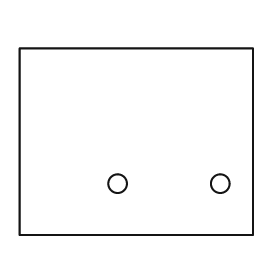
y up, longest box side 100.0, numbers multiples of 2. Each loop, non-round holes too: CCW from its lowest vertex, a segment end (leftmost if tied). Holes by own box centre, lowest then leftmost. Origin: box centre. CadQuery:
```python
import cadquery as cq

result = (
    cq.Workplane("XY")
    .moveTo(-50.0, -40.0)
    .lineTo(50.0, -40.0)
    .lineTo(50.0, 40.0)
    .lineTo(-50.0, 40.0)
    .close()
    .moveTo(-8.0, -18.0)
    .circle(4.0)
    .moveTo(36.0, -18.0)
    .circle(4.0)
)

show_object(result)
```